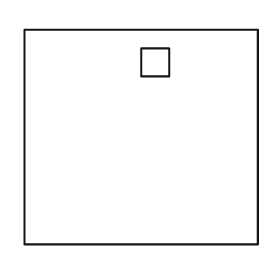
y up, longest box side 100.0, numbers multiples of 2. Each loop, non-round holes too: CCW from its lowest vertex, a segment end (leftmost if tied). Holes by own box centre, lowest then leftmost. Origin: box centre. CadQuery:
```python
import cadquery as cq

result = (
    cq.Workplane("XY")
    .moveTo(-50.0, -46.0)
    .lineTo(50.0, -46.0)
    .lineTo(50.0, 46.0)
    .lineTo(-50.0, 46.0)
    .close()
    .moveTo(0.0, 26.0)
    .lineTo(12.0, 26.0)
    .lineTo(12.0, 38.0)
    .lineTo(0.0, 38.0)
    .close()
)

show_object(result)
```